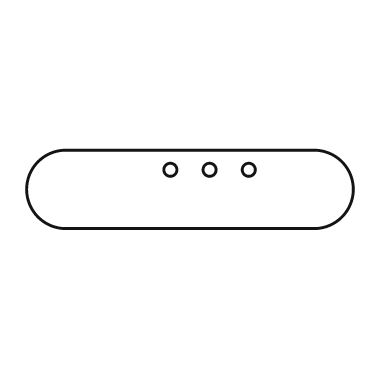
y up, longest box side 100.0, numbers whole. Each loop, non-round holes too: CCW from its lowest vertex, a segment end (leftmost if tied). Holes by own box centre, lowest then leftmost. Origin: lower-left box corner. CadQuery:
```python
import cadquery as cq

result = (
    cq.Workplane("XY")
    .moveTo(12.0, 0.0)
    .lineTo(88.0, 0.0)
    .threePointArc((100.0, 12.0), (88.0, 24.0))
    .lineTo(12.0, 24.0)
    .threePointArc((0.0, 12.0), (12.0, 0.0))
    .close()
    .moveTo(44.0, 18.0)
    .circle(2.0)
    .moveTo(56.0, 18.0)
    .circle(2.0)
    .moveTo(68.0, 18.0)
    .circle(2.0)
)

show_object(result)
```